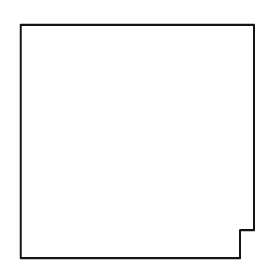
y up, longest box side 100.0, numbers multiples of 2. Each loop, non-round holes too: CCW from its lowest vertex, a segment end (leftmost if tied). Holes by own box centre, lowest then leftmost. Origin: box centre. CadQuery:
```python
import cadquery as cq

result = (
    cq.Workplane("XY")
    .moveTo(-50.0, -50.0)
    .lineTo(44.0, -50.0)
    .lineTo(44.0, -38.0)
    .lineTo(50.0, -38.0)
    .lineTo(50.0, 50.0)
    .lineTo(-50.0, 50.0)
    .close()
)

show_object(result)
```